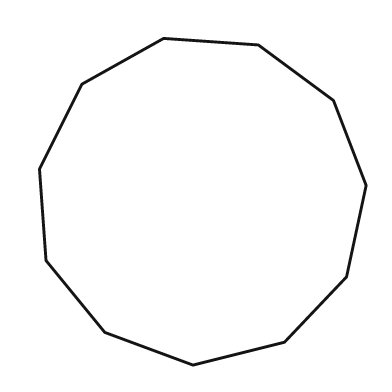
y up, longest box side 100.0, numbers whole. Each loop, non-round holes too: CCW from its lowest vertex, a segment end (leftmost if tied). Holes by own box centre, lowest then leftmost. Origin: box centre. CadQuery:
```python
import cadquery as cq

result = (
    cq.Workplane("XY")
    .moveTo(-3.0, -50.0)
    .lineTo(25.0, -43.0)
    .lineTo(44.0, -23.0)
    .lineTo(50.0, 5.0)
    .lineTo(40.0, 31.0)
    .lineTo(17.0, 48.0)
    .lineTo(-12.0, 50.0)
    .lineTo(-37.0, 36.0)
    .lineTo(-50.0, 10.0)
    .lineTo(-48.0, -18.0)
    .lineTo(-30.0, -40.0)
    .close()
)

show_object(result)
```